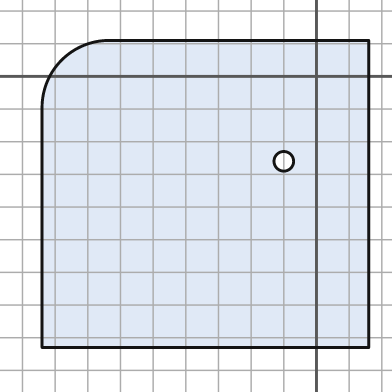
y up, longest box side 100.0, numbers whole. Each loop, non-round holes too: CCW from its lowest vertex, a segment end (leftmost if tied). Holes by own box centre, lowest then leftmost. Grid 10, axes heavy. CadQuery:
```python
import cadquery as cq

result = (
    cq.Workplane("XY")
    .moveTo(-84.0, -83.0)
    .lineTo(16.0, -83.0)
    .lineTo(16.0, 11.0)
    .lineTo(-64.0, 11.0)
    .threePointArc((-78.0, 5.0), (-84.0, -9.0))
    .close()
    .moveTo(-10.0, -26.0)
    .circle(3.0)
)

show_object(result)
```